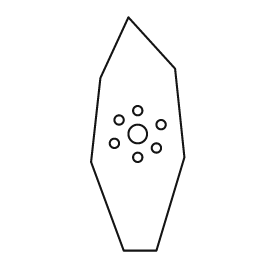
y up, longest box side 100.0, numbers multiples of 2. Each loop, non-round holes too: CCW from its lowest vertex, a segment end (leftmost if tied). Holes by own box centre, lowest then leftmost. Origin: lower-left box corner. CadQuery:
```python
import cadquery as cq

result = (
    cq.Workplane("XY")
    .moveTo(14.0, 0.0)
    .lineTo(28.0, 0.0)
    .lineTo(40.0, 40.0)
    .lineTo(36.0, 78.0)
    .lineTo(16.0, 100.0)
    .lineTo(4.0, 74.0)
    .lineTo(0.0, 38.0)
    .close()
    .moveTo(20.0, 40.0)
    .circle(2.0)
    .moveTo(28.0, 44.0)
    .circle(2.0)
    .moveTo(10.0, 46.0)
    .circle(2.0)
    .moveTo(20.0, 50.0)
    .circle(4.0)
    .moveTo(30.0, 54.0)
    .circle(2.0)
    .moveTo(12.0, 56.0)
    .circle(2.0)
    .moveTo(20.0, 60.0)
    .circle(2.0)
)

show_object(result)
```